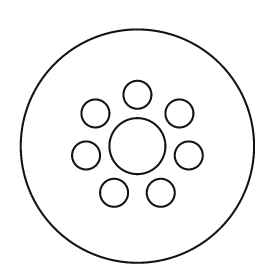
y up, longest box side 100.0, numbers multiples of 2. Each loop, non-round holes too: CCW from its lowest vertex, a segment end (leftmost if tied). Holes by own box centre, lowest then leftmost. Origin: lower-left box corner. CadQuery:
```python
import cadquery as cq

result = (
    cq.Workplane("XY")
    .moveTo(50.0, 50.0)
    .circle(50.0)
    .moveTo(40.0, 30.0)
    .circle(6.0)
    .moveTo(60.0, 30.0)
    .circle(6.0)
    .moveTo(28.0, 46.0)
    .circle(6.0)
    .moveTo(72.0, 46.0)
    .circle(6.0)
    .moveTo(50.0, 50.0)
    .circle(12.0)
    .moveTo(32.0, 64.0)
    .circle(6.0)
    .moveTo(68.0, 64.0)
    .circle(6.0)
    .moveTo(50.0, 72.0)
    .circle(6.0)
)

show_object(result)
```